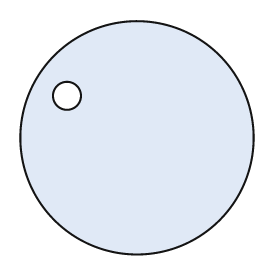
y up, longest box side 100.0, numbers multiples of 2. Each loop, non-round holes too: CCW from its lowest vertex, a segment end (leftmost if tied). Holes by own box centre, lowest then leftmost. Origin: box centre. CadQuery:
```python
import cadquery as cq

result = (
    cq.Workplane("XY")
    .moveTo(0.0, 0.0)
    .circle(50.0)
    .moveTo(-30.0, 18.0)
    .circle(6.0)
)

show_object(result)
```